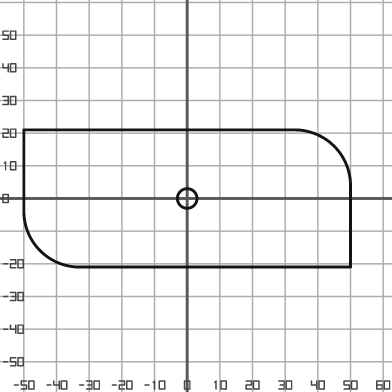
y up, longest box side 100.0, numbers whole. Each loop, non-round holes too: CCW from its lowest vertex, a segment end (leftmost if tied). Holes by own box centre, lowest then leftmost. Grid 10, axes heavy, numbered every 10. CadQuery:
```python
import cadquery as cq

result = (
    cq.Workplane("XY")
    .moveTo(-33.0, -21.0)
    .lineTo(50.0, -21.0)
    .lineTo(50.0, 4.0)
    .threePointArc((45.0, 16.0), (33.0, 21.0))
    .lineTo(-50.0, 21.0)
    .lineTo(-50.0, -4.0)
    .threePointArc((-45.0, -16.0), (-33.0, -21.0))
    .close()
    .moveTo(0.0, 0.0)
    .circle(3.0)
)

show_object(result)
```